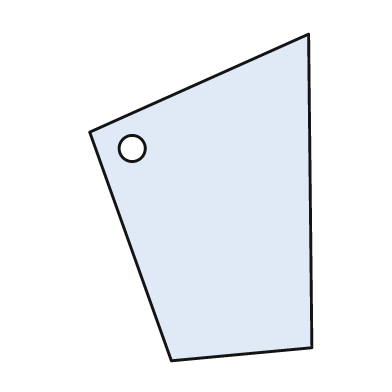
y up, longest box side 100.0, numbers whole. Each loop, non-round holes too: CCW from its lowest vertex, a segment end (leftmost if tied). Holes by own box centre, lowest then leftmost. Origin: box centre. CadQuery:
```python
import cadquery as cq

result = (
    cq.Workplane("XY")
    .moveTo(-9.0, -50.0)
    .lineTo(34.0, -46.0)
    .lineTo(33.0, 50.0)
    .lineTo(-34.0, 20.0)
    .close()
    .moveTo(-21.0, 15.0)
    .circle(4.0)
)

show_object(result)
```